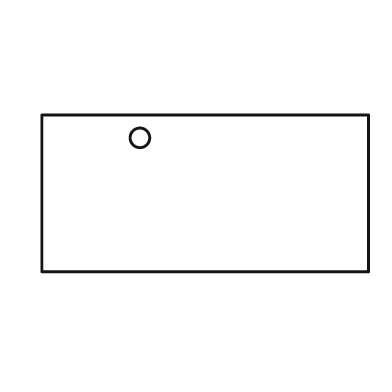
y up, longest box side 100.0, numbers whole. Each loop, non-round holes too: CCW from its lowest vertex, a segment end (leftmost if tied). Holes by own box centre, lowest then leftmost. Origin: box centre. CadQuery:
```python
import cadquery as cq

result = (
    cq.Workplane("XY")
    .moveTo(-50.0, -24.0)
    .lineTo(50.0, -24.0)
    .lineTo(50.0, 24.0)
    .lineTo(-50.0, 24.0)
    .close()
    .moveTo(-20.0, 17.0)
    .circle(3.0)
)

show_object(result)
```